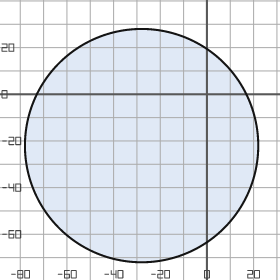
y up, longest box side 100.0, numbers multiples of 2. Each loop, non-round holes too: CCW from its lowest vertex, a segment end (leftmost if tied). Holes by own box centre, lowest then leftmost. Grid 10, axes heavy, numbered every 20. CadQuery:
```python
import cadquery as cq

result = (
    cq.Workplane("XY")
    .moveTo(-28.0, -22.0)
    .circle(50.0)
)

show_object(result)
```